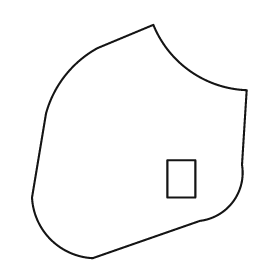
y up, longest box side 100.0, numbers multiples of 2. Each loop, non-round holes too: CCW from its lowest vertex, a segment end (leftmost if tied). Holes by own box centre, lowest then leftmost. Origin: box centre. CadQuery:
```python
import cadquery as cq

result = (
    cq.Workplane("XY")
    .moveTo(-20.0, -50.0)
    .lineTo(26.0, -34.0)
    .threePointArc((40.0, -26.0), (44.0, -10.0))
    .lineTo(46.0, 22.0)
    .threePointArc((22.0, 30.0), (6.0, 50.0))
    .lineTo(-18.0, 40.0)
    .threePointArc((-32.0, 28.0), (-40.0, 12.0))
    .lineTo(-46.0, -24.0)
    .threePointArc((-38.0, -42.0), (-20.0, -50.0))
    .close()
    .moveTo(12.0, -24.0)
    .lineTo(24.0, -24.0)
    .lineTo(24.0, -8.0)
    .lineTo(12.0, -8.0)
    .close()
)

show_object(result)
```